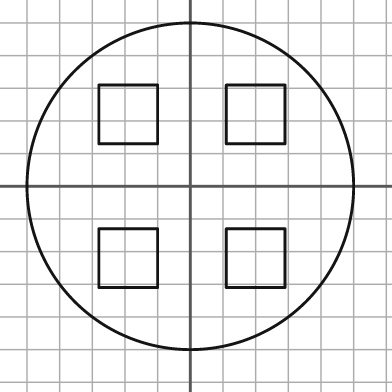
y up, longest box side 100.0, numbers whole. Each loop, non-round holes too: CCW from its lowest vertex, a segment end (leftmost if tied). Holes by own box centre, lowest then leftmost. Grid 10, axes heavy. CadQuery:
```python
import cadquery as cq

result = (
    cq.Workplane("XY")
    .moveTo(0.0, 0.0)
    .circle(50.0)
    .moveTo(-28.0, -31.0)
    .lineTo(-10.0, -31.0)
    .lineTo(-10.0, -13.0)
    .lineTo(-28.0, -13.0)
    .close()
    .moveTo(11.0, -31.0)
    .lineTo(29.0, -31.0)
    .lineTo(29.0, -13.0)
    .lineTo(11.0, -13.0)
    .close()
    .moveTo(-28.0, 13.0)
    .lineTo(-10.0, 13.0)
    .lineTo(-10.0, 31.0)
    .lineTo(-28.0, 31.0)
    .close()
    .moveTo(11.0, 13.0)
    .lineTo(29.0, 13.0)
    .lineTo(29.0, 31.0)
    .lineTo(11.0, 31.0)
    .close()
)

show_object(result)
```